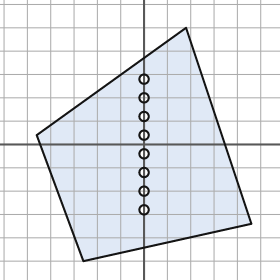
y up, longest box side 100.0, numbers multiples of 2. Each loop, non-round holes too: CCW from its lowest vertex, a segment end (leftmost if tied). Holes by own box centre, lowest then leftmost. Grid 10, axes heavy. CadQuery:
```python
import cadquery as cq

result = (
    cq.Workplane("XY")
    .moveTo(-26.0, -50.0)
    .lineTo(46.0, -34.0)
    .lineTo(18.0, 50.0)
    .lineTo(-46.0, 4.0)
    .close()
    .moveTo(0.0, -28.0)
    .circle(2.0)
    .moveTo(0.0, -20.0)
    .circle(2.0)
    .moveTo(0.0, -12.0)
    .circle(2.0)
    .moveTo(0.0, -4.0)
    .circle(2.0)
    .moveTo(0.0, 4.0)
    .circle(2.0)
    .moveTo(0.0, 12.0)
    .circle(2.0)
    .moveTo(0.0, 20.0)
    .circle(2.0)
    .moveTo(0.0, 28.0)
    .circle(2.0)
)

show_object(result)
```